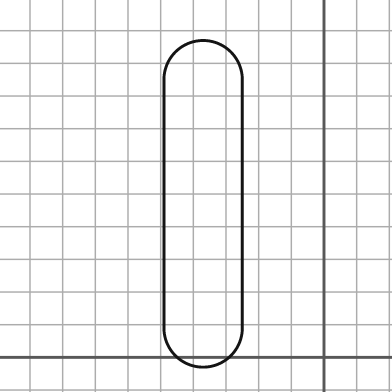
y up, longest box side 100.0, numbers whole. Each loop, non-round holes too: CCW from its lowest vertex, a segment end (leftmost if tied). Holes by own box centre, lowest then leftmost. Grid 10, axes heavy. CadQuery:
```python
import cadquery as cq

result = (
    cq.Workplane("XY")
    .moveTo(-49.0, 9.0)
    .threePointArc((-37.0, -3.0), (-25.0, 9.0))
    .lineTo(-25.0, 85.0)
    .threePointArc((-37.0, 97.0), (-49.0, 85.0))
    .close()
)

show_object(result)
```